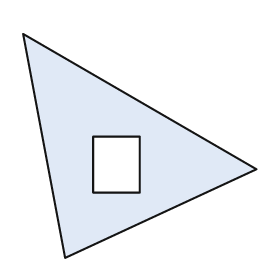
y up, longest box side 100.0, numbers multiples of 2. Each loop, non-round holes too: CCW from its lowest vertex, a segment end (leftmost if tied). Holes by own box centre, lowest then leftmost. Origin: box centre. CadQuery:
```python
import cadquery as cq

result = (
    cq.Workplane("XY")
    .moveTo(-32.0, -48.0)
    .lineTo(50.0, -10.0)
    .lineTo(-50.0, 48.0)
    .close()
    .moveTo(-20.0, -20.0)
    .lineTo(0.0, -20.0)
    .lineTo(0.0, 4.0)
    .lineTo(-20.0, 4.0)
    .close()
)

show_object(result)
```